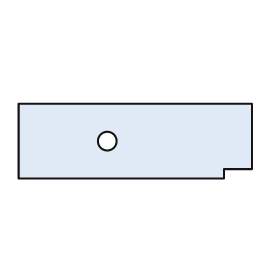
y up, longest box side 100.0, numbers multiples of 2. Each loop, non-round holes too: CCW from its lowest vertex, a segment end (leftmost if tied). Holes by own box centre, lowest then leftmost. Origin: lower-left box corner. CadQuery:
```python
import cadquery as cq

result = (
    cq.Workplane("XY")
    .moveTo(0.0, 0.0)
    .lineTo(88.0, 0.0)
    .lineTo(88.0, 4.0)
    .lineTo(100.0, 4.0)
    .lineTo(100.0, 32.0)
    .lineTo(0.0, 32.0)
    .close()
    .moveTo(38.0, 16.0)
    .circle(4.0)
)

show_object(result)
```